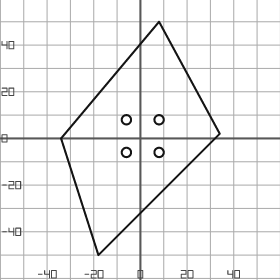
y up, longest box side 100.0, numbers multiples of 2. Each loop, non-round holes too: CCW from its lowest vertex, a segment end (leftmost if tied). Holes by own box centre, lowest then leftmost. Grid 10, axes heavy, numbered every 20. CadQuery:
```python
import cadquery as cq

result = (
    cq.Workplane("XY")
    .moveTo(-18.0, -50.0)
    .lineTo(34.0, 2.0)
    .lineTo(8.0, 50.0)
    .lineTo(-34.0, 0.0)
    .close()
    .moveTo(-6.0, -6.0)
    .circle(2.0)
    .moveTo(8.0, -6.0)
    .circle(2.0)
    .moveTo(-6.0, 8.0)
    .circle(2.0)
    .moveTo(8.0, 8.0)
    .circle(2.0)
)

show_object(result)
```